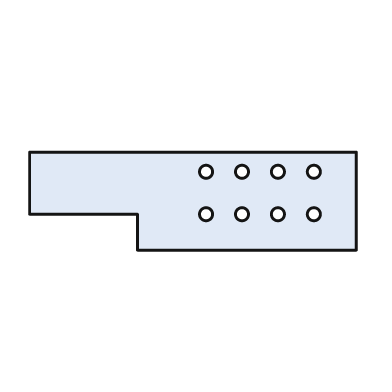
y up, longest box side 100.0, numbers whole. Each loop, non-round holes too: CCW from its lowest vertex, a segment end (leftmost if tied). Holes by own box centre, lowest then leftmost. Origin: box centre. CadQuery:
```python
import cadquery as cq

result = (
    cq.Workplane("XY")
    .moveTo(-17.0, -15.0)
    .lineTo(50.0, -15.0)
    .lineTo(50.0, 15.0)
    .lineTo(-50.0, 15.0)
    .lineTo(-50.0, -4.0)
    .lineTo(-17.0, -4.0)
    .close()
    .moveTo(4.0, -4.0)
    .circle(2.0)
    .moveTo(15.0, -4.0)
    .circle(2.0)
    .moveTo(26.0, -4.0)
    .circle(2.0)
    .moveTo(37.0, -4.0)
    .circle(2.0)
    .moveTo(4.0, 9.0)
    .circle(2.0)
    .moveTo(15.0, 9.0)
    .circle(2.0)
    .moveTo(26.0, 9.0)
    .circle(2.0)
    .moveTo(37.0, 9.0)
    .circle(2.0)
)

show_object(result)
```